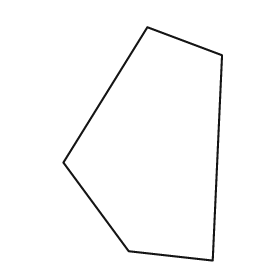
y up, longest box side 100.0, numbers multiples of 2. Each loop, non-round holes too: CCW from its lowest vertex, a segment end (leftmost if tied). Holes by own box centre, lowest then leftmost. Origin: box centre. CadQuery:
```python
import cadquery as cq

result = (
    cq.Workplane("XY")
    .moveTo(30.0, -50.0)
    .lineTo(34.0, 38.0)
    .lineTo(2.0, 50.0)
    .lineTo(-34.0, -8.0)
    .lineTo(-6.0, -46.0)
    .close()
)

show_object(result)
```